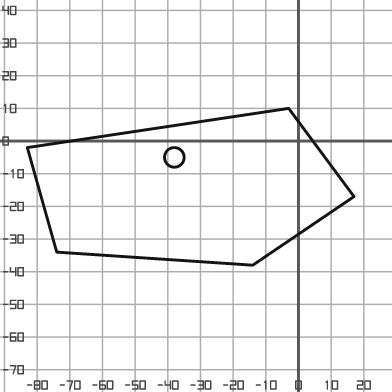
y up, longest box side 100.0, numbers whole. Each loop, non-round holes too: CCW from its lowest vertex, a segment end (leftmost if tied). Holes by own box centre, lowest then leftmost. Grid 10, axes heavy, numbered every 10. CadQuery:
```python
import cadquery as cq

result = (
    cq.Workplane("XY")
    .moveTo(-14.0, -38.0)
    .lineTo(17.0, -17.0)
    .lineTo(-3.0, 10.0)
    .lineTo(-83.0, -2.0)
    .lineTo(-74.0, -34.0)
    .close()
    .moveTo(-38.0, -5.0)
    .circle(3.0)
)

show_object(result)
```